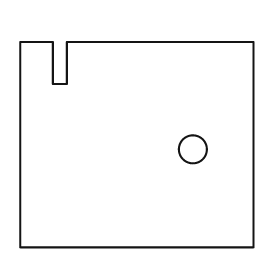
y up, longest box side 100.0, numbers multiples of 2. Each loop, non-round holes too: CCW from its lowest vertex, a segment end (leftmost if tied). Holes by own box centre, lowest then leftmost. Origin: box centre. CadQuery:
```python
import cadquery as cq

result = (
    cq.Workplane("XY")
    .moveTo(-50.0, -44.0)
    .lineTo(50.0, -44.0)
    .lineTo(50.0, 44.0)
    .lineTo(-30.0, 44.0)
    .lineTo(-30.0, 26.0)
    .lineTo(-36.0, 26.0)
    .lineTo(-36.0, 44.0)
    .lineTo(-50.0, 44.0)
    .close()
    .moveTo(24.0, -2.0)
    .circle(6.0)
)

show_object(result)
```